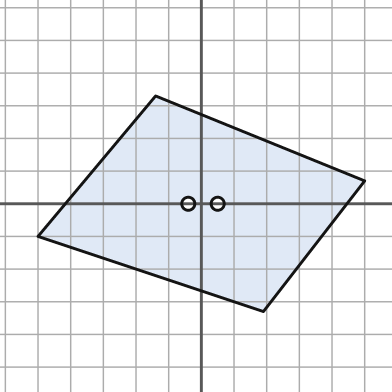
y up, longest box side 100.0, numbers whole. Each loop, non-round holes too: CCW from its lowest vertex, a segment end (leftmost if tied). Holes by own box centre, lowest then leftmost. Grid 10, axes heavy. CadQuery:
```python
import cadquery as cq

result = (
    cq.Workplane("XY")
    .moveTo(19.0, -33.0)
    .lineTo(50.0, 7.0)
    .lineTo(-14.0, 33.0)
    .lineTo(-50.0, -10.0)
    .close()
    .moveTo(-4.0, 0.0)
    .circle(2.0)
    .moveTo(5.0, 0.0)
    .circle(2.0)
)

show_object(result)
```